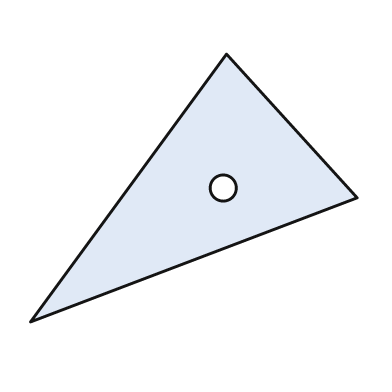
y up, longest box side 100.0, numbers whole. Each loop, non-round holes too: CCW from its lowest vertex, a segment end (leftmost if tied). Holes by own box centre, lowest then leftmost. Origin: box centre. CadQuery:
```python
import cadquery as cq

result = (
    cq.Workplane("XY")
    .moveTo(-50.0, -41.0)
    .lineTo(50.0, -3.0)
    .lineTo(10.0, 41.0)
    .close()
    .moveTo(9.0, 0.0)
    .circle(4.0)
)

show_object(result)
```